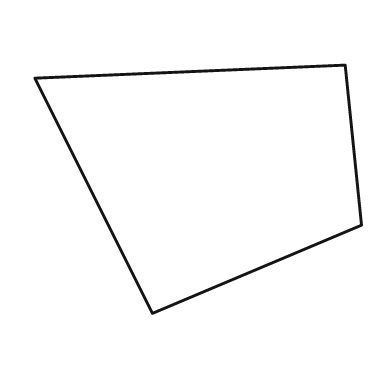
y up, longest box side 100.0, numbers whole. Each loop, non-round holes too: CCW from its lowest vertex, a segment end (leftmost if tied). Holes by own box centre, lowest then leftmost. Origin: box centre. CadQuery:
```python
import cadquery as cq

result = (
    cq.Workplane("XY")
    .moveTo(-14.0, -38.0)
    .lineTo(50.0, -11.0)
    .lineTo(45.0, 38.0)
    .lineTo(-50.0, 34.0)
    .close()
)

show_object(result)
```